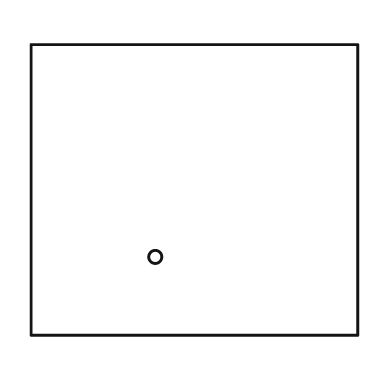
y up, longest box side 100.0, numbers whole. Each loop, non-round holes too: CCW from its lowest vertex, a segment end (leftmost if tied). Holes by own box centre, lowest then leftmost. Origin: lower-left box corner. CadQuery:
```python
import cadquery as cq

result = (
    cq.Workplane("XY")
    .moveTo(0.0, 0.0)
    .lineTo(100.0, 0.0)
    .lineTo(100.0, 89.0)
    .lineTo(0.0, 89.0)
    .close()
    .moveTo(38.0, 24.0)
    .circle(2.0)
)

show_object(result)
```